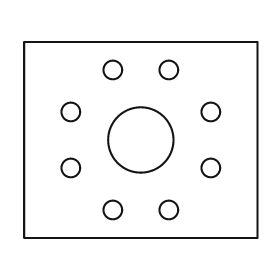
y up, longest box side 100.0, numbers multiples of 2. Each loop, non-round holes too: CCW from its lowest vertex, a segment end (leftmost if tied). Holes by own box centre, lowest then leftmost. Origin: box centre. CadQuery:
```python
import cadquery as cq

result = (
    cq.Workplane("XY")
    .moveTo(-50.0, -42.0)
    .lineTo(50.0, -42.0)
    .lineTo(50.0, 42.0)
    .lineTo(-50.0, 42.0)
    .close()
    .moveTo(-12.0, -30.0)
    .circle(4.0)
    .moveTo(12.0, -30.0)
    .circle(4.0)
    .moveTo(-30.0, -12.0)
    .circle(4.0)
    .moveTo(30.0, -12.0)
    .circle(4.0)
    .moveTo(0.0, 0.0)
    .circle(14.0)
    .moveTo(-30.0, 12.0)
    .circle(4.0)
    .moveTo(30.0, 12.0)
    .circle(4.0)
    .moveTo(-12.0, 30.0)
    .circle(4.0)
    .moveTo(12.0, 30.0)
    .circle(4.0)
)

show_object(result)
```